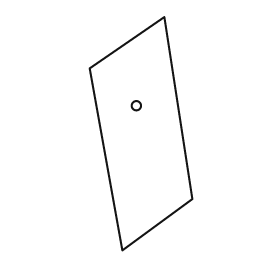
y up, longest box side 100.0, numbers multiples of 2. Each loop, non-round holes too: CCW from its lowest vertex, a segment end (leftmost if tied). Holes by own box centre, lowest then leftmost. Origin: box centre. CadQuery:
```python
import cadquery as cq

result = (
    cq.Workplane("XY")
    .moveTo(-8.0, -50.0)
    .lineTo(22.0, -28.0)
    .lineTo(10.0, 50.0)
    .lineTo(-22.0, 28.0)
    .close()
    .moveTo(-2.0, 12.0)
    .circle(2.0)
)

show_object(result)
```